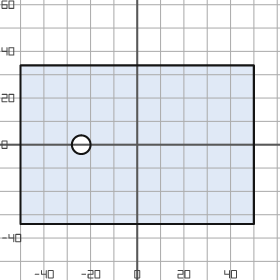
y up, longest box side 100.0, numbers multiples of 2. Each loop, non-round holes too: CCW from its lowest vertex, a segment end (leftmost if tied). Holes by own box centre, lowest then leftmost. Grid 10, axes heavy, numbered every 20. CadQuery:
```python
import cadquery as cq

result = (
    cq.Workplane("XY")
    .moveTo(-50.0, -34.0)
    .lineTo(50.0, -34.0)
    .lineTo(50.0, 34.0)
    .lineTo(-50.0, 34.0)
    .close()
    .moveTo(-24.0, 0.0)
    .circle(4.0)
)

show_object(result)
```